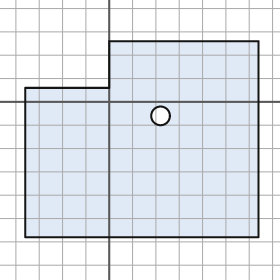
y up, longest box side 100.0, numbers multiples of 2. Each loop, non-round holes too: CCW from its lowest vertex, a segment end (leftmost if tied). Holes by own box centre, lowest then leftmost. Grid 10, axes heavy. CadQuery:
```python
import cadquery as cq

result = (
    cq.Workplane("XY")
    .moveTo(-36.0, -58.0)
    .lineTo(64.0, -58.0)
    .lineTo(64.0, 26.0)
    .lineTo(0.0, 26.0)
    .lineTo(0.0, 6.0)
    .lineTo(-36.0, 6.0)
    .close()
    .moveTo(22.0, -6.0)
    .circle(4.0)
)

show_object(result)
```